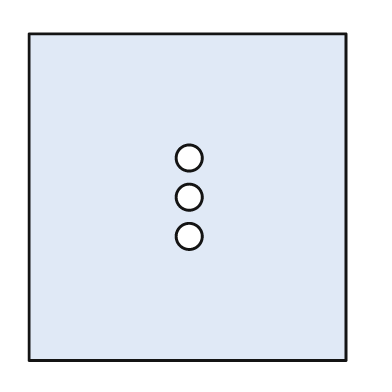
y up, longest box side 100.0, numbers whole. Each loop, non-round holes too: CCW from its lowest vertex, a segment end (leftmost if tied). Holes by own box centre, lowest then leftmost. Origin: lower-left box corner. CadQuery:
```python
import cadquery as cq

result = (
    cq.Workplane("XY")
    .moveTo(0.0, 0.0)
    .lineTo(97.0, 0.0)
    .lineTo(97.0, 100.0)
    .lineTo(0.0, 100.0)
    .close()
    .moveTo(49.0, 38.0)
    .circle(4.0)
    .moveTo(49.0, 50.0)
    .circle(4.0)
    .moveTo(49.0, 62.0)
    .circle(4.0)
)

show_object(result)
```